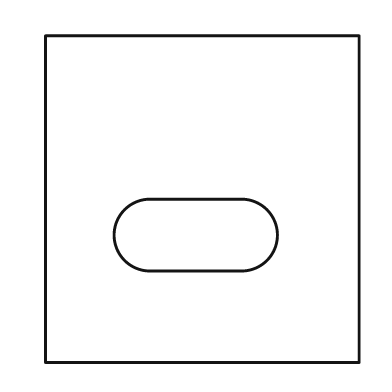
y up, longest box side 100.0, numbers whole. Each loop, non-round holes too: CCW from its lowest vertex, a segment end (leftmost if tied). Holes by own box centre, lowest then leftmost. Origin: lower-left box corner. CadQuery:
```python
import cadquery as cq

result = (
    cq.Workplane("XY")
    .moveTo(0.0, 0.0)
    .lineTo(96.0, 0.0)
    .lineTo(96.0, 100.0)
    .lineTo(0.0, 100.0)
    .close()
    .moveTo(32.0, 28.0)
    .lineTo(60.0, 28.0)
    .threePointArc((71.0, 39.0), (60.0, 50.0))
    .lineTo(32.0, 50.0)
    .threePointArc((21.0, 39.0), (32.0, 28.0))
    .close()
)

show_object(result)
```